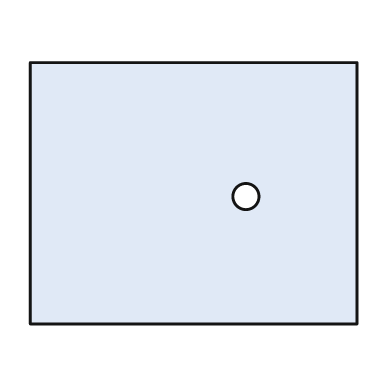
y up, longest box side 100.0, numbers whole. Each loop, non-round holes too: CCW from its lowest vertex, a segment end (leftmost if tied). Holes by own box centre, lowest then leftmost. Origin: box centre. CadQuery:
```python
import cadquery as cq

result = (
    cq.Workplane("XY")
    .moveTo(-50.0, -40.0)
    .lineTo(50.0, -40.0)
    .lineTo(50.0, 40.0)
    .lineTo(-50.0, 40.0)
    .close()
    .moveTo(16.0, -1.0)
    .circle(4.0)
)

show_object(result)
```